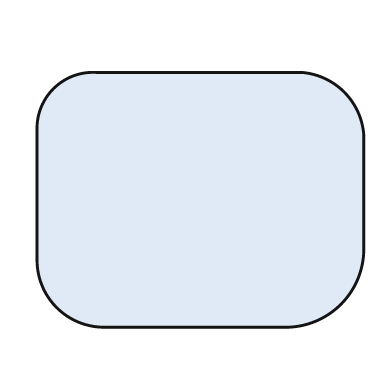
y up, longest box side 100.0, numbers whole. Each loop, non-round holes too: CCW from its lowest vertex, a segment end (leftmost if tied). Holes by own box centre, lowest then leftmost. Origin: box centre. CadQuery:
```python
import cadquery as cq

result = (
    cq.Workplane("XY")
    .moveTo(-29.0, -39.0)
    .lineTo(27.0, -39.0)
    .threePointArc((43.0, -32.0), (50.0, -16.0))
    .lineTo(50.0, 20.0)
    .threePointArc((44.0, 33.0), (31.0, 39.0))
    .lineTo(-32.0, 39.0)
    .threePointArc((-45.0, 34.0), (-50.0, 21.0))
    .lineTo(-50.0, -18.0)
    .threePointArc((-44.0, -33.0), (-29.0, -39.0))
    .close()
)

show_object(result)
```